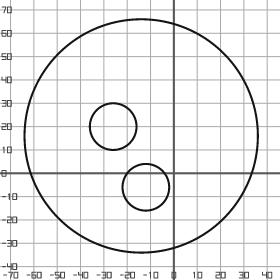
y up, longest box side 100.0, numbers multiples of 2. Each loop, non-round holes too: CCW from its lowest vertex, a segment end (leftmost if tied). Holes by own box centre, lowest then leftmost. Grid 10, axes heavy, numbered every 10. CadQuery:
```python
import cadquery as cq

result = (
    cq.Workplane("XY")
    .moveTo(-14.0, 16.0)
    .circle(50.0)
    .moveTo(-12.0, -6.0)
    .circle(10.0)
    .moveTo(-26.0, 20.0)
    .circle(10.0)
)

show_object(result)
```